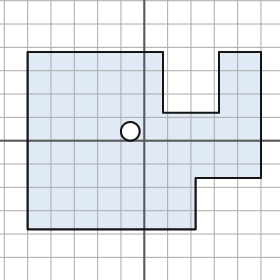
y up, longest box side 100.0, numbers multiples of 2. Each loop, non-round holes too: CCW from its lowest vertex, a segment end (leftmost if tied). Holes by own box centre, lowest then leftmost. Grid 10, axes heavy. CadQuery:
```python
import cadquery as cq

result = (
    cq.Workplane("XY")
    .moveTo(-50.0, -38.0)
    .lineTo(22.0, -38.0)
    .lineTo(22.0, -16.0)
    .lineTo(50.0, -16.0)
    .lineTo(50.0, 38.0)
    .lineTo(32.0, 38.0)
    .lineTo(32.0, 12.0)
    .lineTo(8.0, 12.0)
    .lineTo(8.0, 38.0)
    .lineTo(-50.0, 38.0)
    .close()
    .moveTo(-6.0, 4.0)
    .circle(4.0)
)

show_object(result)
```